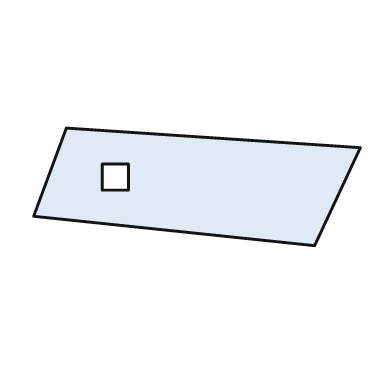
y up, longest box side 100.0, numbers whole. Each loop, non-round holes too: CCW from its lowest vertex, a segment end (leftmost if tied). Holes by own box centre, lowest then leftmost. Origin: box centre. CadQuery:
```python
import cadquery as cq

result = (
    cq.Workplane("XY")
    .moveTo(36.0, -18.0)
    .lineTo(50.0, 12.0)
    .lineTo(-40.0, 18.0)
    .lineTo(-50.0, -9.0)
    .close()
    .moveTo(-29.0, -1.0)
    .lineTo(-21.0, -1.0)
    .lineTo(-21.0, 7.0)
    .lineTo(-29.0, 7.0)
    .close()
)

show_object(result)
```